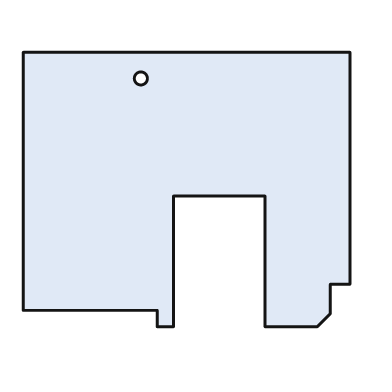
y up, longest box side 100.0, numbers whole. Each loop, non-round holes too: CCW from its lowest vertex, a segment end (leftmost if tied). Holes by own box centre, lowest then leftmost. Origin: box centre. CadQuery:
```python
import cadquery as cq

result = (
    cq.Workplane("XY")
    .moveTo(-9.0, -42.0)
    .lineTo(-4.0, -42.0)
    .lineTo(-4.0, -2.0)
    .lineTo(24.0, -2.0)
    .lineTo(24.0, -42.0)
    .lineTo(40.0, -42.0)
    .lineTo(44.0, -38.0)
    .lineTo(44.0, -29.0)
    .lineTo(50.0, -29.0)
    .lineTo(50.0, 42.0)
    .lineTo(-50.0, 42.0)
    .lineTo(-50.0, -37.0)
    .lineTo(-9.0, -37.0)
    .close()
    .moveTo(-14.0, 34.0)
    .circle(2.0)
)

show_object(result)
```